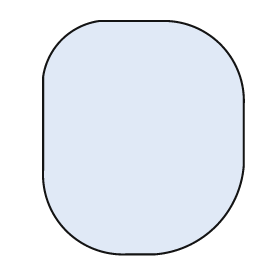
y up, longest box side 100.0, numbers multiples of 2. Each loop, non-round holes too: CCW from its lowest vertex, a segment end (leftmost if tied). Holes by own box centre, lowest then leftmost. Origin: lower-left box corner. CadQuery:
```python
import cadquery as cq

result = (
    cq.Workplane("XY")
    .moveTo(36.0, 0.0)
    .lineTo(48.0, 0.0)
    .threePointArc((74.0, 12.0), (86.0, 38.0))
    .lineTo(86.0, 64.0)
    .threePointArc((76.0, 90.0), (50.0, 100.0))
    .lineTo(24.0, 100.0)
    .threePointArc((8.0, 92.0), (0.0, 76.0))
    .lineTo(0.0, 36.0)
    .threePointArc((10.0, 10.0), (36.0, 0.0))
    .close()
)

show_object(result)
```